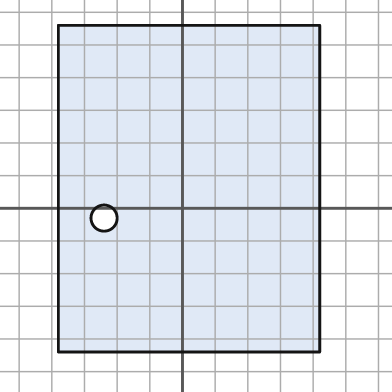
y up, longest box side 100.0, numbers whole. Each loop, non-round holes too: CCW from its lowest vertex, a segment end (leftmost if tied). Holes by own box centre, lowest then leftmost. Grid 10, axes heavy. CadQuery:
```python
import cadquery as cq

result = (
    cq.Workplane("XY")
    .moveTo(-38.0, -44.0)
    .lineTo(42.0, -44.0)
    .lineTo(42.0, 56.0)
    .lineTo(-38.0, 56.0)
    .close()
    .moveTo(-24.0, -3.0)
    .circle(4.0)
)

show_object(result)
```